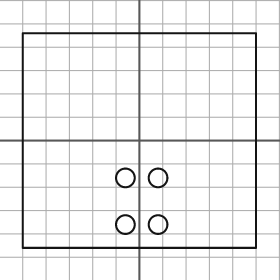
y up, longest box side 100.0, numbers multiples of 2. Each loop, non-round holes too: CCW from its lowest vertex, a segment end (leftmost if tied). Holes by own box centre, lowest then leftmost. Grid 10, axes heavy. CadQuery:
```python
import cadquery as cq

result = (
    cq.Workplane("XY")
    .moveTo(-50.0, -46.0)
    .lineTo(50.0, -46.0)
    .lineTo(50.0, 46.0)
    .lineTo(-50.0, 46.0)
    .close()
    .moveTo(-6.0, -36.0)
    .circle(4.0)
    .moveTo(8.0, -36.0)
    .circle(4.0)
    .moveTo(-6.0, -16.0)
    .circle(4.0)
    .moveTo(8.0, -16.0)
    .circle(4.0)
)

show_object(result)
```